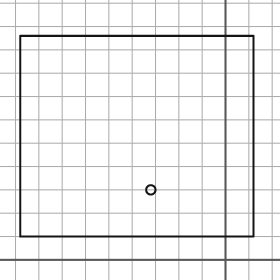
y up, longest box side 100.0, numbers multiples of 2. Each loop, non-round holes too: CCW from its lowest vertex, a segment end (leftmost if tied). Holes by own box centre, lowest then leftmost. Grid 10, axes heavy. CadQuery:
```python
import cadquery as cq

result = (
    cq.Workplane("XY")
    .moveTo(-88.0, 10.0)
    .lineTo(12.0, 10.0)
    .lineTo(12.0, 96.0)
    .lineTo(-88.0, 96.0)
    .close()
    .moveTo(-32.0, 30.0)
    .circle(2.0)
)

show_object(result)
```